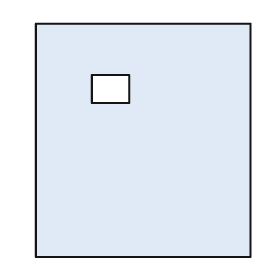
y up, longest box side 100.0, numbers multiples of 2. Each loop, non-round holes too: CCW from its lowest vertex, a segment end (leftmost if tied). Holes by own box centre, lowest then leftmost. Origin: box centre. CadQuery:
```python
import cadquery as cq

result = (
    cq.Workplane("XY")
    .moveTo(-46.0, -50.0)
    .lineTo(46.0, -50.0)
    .lineTo(46.0, 50.0)
    .lineTo(-46.0, 50.0)
    .close()
    .moveTo(-22.0, 16.0)
    .lineTo(-6.0, 16.0)
    .lineTo(-6.0, 28.0)
    .lineTo(-22.0, 28.0)
    .close()
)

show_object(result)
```